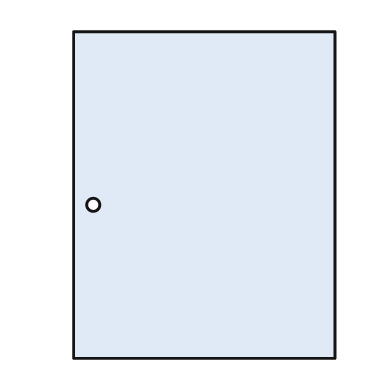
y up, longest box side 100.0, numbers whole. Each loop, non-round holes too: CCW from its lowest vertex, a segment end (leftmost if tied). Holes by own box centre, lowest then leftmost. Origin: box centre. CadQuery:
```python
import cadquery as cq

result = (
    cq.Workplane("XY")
    .moveTo(-40.0, -50.0)
    .lineTo(40.0, -50.0)
    .lineTo(40.0, 50.0)
    .lineTo(-40.0, 50.0)
    .close()
    .moveTo(-34.0, -3.0)
    .circle(2.0)
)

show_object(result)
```